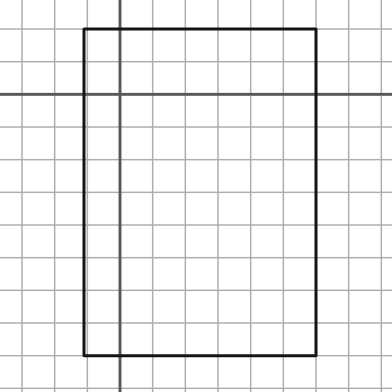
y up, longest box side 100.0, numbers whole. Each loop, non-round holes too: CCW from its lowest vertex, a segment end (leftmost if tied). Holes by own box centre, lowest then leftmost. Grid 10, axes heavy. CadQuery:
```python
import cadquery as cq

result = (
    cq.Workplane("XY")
    .moveTo(-11.0, -80.0)
    .lineTo(60.0, -80.0)
    .lineTo(60.0, 20.0)
    .lineTo(-11.0, 20.0)
    .close()
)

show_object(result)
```